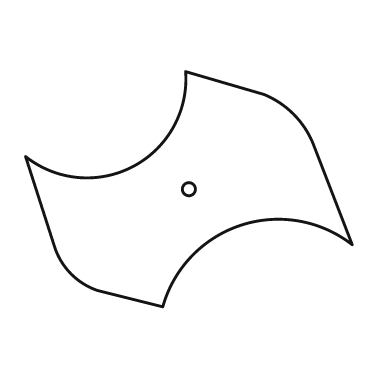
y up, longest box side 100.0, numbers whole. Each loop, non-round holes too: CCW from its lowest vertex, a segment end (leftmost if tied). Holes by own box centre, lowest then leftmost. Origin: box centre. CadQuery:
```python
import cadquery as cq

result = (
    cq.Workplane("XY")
    .moveTo(-8.0, -36.0)
    .threePointArc((16.0, -11.0), (50.0, -17.0))
    .lineTo(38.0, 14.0)
    .threePointArc((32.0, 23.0), (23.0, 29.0))
    .lineTo(-1.0, 36.0)
    .threePointArc((-17.0, 7.0), (-50.0, 10.0))
    .lineTo(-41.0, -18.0)
    .threePointArc((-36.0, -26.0), (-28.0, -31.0))
    .close()
    .moveTo(0.0, 0.0)
    .circle(2.0)
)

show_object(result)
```